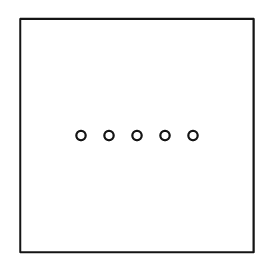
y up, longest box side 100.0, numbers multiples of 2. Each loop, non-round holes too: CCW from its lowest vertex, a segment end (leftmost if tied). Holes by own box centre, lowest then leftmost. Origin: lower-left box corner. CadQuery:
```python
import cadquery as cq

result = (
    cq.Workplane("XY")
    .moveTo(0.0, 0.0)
    .lineTo(100.0, 0.0)
    .lineTo(100.0, 100.0)
    .lineTo(0.0, 100.0)
    .close()
    .moveTo(26.0, 50.0)
    .circle(2.0)
    .moveTo(38.0, 50.0)
    .circle(2.0)
    .moveTo(50.0, 50.0)
    .circle(2.0)
    .moveTo(62.0, 50.0)
    .circle(2.0)
    .moveTo(74.0, 50.0)
    .circle(2.0)
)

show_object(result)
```